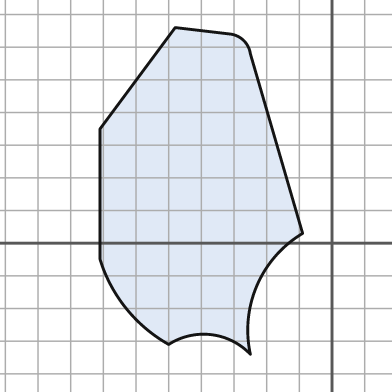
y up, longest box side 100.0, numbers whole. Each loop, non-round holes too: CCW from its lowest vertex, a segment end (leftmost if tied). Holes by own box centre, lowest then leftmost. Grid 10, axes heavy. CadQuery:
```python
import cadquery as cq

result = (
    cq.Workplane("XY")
    .moveTo(-25.0, -34.0)
    .threePointArc((-23.0, -13.0), (-9.0, 3.0))
    .lineTo(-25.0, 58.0)
    .threePointArc((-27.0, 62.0), (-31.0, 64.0))
    .lineTo(-48.0, 66.0)
    .lineTo(-71.0, 35.0)
    .lineTo(-71.0, -5.0)
    .threePointArc((-63.0, -20.0), (-50.0, -31.0))
    .threePointArc((-37.0, -28.0), (-25.0, -34.0))
    .close()
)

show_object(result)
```